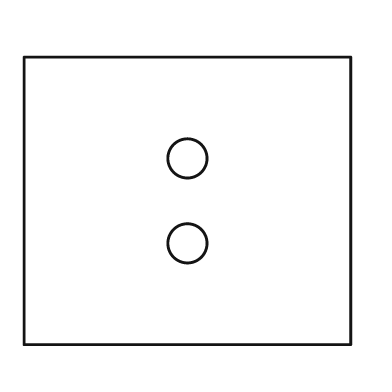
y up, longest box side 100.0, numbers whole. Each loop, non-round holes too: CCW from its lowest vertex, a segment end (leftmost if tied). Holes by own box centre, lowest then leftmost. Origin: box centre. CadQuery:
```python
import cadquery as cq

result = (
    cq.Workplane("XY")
    .moveTo(-50.0, -44.0)
    .lineTo(50.0, -44.0)
    .lineTo(50.0, 44.0)
    .lineTo(-50.0, 44.0)
    .close()
    .moveTo(0.0, -13.0)
    .circle(6.0)
    .moveTo(0.0, 13.0)
    .circle(6.0)
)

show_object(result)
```